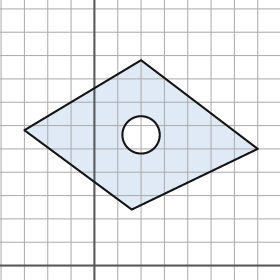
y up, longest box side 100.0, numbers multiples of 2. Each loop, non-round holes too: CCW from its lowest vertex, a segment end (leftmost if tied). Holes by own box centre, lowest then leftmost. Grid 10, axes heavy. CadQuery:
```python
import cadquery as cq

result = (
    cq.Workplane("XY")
    .moveTo(16.0, 24.0)
    .lineTo(70.0, 50.0)
    .lineTo(20.0, 88.0)
    .lineTo(-30.0, 58.0)
    .close()
    .moveTo(20.0, 56.0)
    .circle(8.0)
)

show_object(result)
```